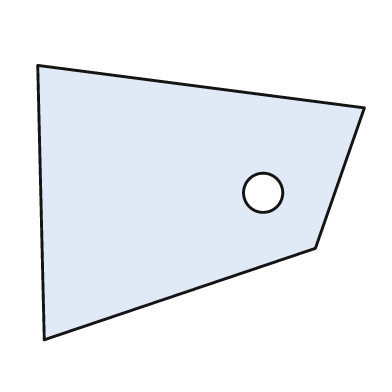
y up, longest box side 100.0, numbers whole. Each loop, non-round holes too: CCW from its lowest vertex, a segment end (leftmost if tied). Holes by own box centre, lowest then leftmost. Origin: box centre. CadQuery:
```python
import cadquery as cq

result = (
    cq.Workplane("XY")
    .moveTo(-48.0, -42.0)
    .lineTo(35.0, -14.0)
    .lineTo(50.0, 29.0)
    .lineTo(-50.0, 42.0)
    .close()
    .moveTo(19.0, 3.0)
    .circle(6.0)
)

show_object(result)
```